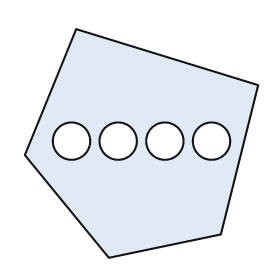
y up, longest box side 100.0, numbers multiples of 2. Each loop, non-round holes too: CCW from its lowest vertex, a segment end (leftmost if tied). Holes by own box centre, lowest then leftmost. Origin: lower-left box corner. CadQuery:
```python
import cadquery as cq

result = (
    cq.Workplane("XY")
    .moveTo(36.0, 0.0)
    .lineTo(84.0, 10.0)
    .lineTo(100.0, 74.0)
    .lineTo(22.0, 98.0)
    .lineTo(0.0, 44.0)
    .close()
    .moveTo(20.0, 50.0)
    .circle(8.0)
    .moveTo(40.0, 50.0)
    .circle(8.0)
    .moveTo(60.0, 50.0)
    .circle(8.0)
    .moveTo(80.0, 50.0)
    .circle(8.0)
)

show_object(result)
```